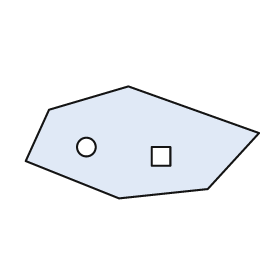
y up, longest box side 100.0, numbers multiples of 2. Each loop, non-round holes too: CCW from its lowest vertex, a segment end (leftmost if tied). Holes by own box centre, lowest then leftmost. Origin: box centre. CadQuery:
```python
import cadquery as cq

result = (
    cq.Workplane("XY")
    .moveTo(-10.0, -24.0)
    .lineTo(28.0, -20.0)
    .lineTo(50.0, 4.0)
    .lineTo(-6.0, 24.0)
    .lineTo(-40.0, 14.0)
    .lineTo(-50.0, -8.0)
    .close()
    .moveTo(4.0, -10.0)
    .lineTo(12.0, -10.0)
    .lineTo(12.0, -2.0)
    .lineTo(4.0, -2.0)
    .close()
    .moveTo(-24.0, -2.0)
    .circle(4.0)
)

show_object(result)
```